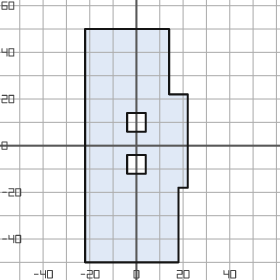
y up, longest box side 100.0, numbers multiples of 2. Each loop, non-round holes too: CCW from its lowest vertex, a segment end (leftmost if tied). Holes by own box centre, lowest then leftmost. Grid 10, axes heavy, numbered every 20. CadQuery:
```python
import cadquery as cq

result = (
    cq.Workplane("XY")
    .moveTo(-22.0, -50.0)
    .lineTo(18.0, -50.0)
    .lineTo(18.0, -18.0)
    .lineTo(22.0, -18.0)
    .lineTo(22.0, 22.0)
    .lineTo(14.0, 22.0)
    .lineTo(14.0, 50.0)
    .lineTo(-22.0, 50.0)
    .close()
    .moveTo(-4.0, -12.0)
    .lineTo(4.0, -12.0)
    .lineTo(4.0, -4.0)
    .lineTo(-4.0, -4.0)
    .close()
    .moveTo(-4.0, 6.0)
    .lineTo(4.0, 6.0)
    .lineTo(4.0, 14.0)
    .lineTo(-4.0, 14.0)
    .close()
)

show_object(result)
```